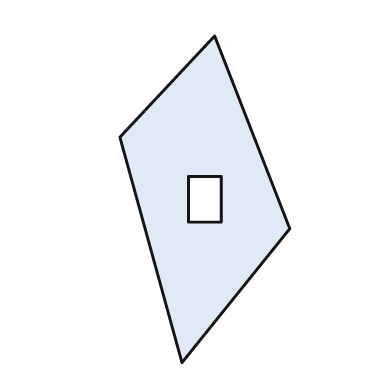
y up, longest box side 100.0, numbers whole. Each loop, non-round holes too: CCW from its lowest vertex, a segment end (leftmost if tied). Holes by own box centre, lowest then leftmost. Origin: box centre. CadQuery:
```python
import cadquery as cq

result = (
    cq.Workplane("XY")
    .moveTo(-7.0, -50.0)
    .lineTo(26.0, -9.0)
    .lineTo(3.0, 50.0)
    .lineTo(-26.0, 19.0)
    .close()
    .moveTo(-5.0, -7.0)
    .lineTo(5.0, -7.0)
    .lineTo(5.0, 7.0)
    .lineTo(-5.0, 7.0)
    .close()
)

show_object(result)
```